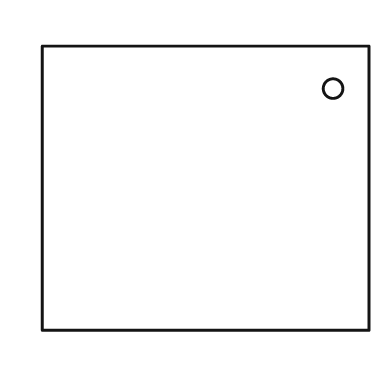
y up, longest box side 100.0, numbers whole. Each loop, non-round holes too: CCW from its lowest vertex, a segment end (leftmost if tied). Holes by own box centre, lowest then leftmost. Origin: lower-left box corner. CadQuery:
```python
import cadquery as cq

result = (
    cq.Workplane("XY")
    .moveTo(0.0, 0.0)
    .lineTo(100.0, 0.0)
    .lineTo(100.0, 87.0)
    .lineTo(0.0, 87.0)
    .close()
    .moveTo(89.0, 74.0)
    .circle(3.0)
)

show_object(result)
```